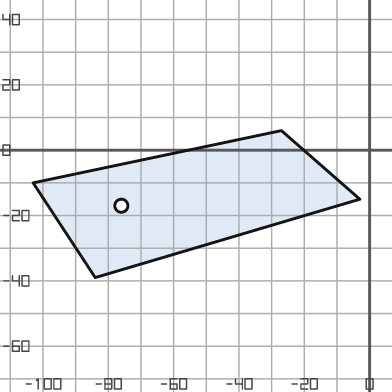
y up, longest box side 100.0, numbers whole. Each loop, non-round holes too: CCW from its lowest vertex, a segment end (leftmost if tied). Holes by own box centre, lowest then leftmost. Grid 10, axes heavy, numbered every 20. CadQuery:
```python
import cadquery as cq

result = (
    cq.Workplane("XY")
    .moveTo(-84.0, -39.0)
    .lineTo(-3.0, -15.0)
    .lineTo(-27.0, 6.0)
    .lineTo(-103.0, -10.0)
    .close()
    .moveTo(-76.0, -17.0)
    .circle(2.0)
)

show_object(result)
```